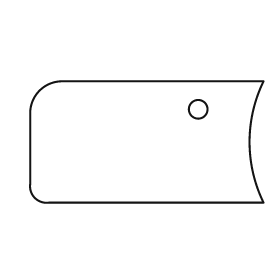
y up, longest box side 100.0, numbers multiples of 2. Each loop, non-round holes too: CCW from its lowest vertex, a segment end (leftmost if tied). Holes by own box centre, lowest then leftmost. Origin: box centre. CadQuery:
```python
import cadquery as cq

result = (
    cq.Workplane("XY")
    .moveTo(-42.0, -26.0)
    .lineTo(50.0, -26.0)
    .threePointArc((44.0, 0.0), (50.0, 26.0))
    .lineTo(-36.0, 26.0)
    .threePointArc((-46.0, 22.0), (-50.0, 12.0))
    .lineTo(-50.0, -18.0)
    .threePointArc((-48.0, -24.0), (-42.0, -26.0))
    .close()
    .moveTo(22.0, 14.0)
    .circle(4.0)
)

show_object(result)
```